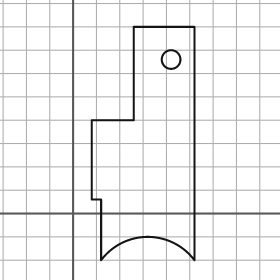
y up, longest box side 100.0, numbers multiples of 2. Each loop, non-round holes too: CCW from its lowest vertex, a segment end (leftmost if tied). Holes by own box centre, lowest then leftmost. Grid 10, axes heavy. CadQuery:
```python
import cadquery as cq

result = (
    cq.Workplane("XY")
    .moveTo(12.0, -20.0)
    .threePointArc((32.0, -10.0), (52.0, -20.0))
    .lineTo(52.0, 80.0)
    .lineTo(26.0, 80.0)
    .lineTo(26.0, 40.0)
    .lineTo(8.0, 40.0)
    .lineTo(8.0, 6.0)
    .lineTo(12.0, 6.0)
    .close()
    .moveTo(42.0, 66.0)
    .circle(4.0)
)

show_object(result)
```